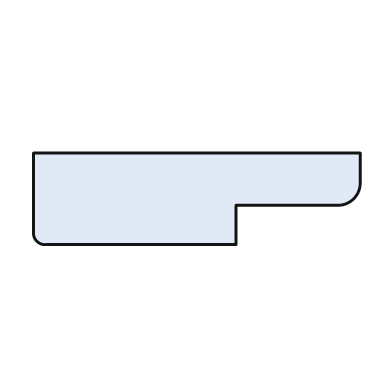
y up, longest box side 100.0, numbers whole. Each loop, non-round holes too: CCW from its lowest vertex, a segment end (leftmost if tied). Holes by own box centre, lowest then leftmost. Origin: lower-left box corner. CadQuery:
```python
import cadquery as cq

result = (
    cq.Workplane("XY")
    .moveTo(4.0, 0.0)
    .lineTo(62.0, 0.0)
    .lineTo(62.0, 12.0)
    .lineTo(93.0, 12.0)
    .threePointArc((98.0, 14.0), (100.0, 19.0))
    .lineTo(100.0, 28.0)
    .lineTo(0.0, 28.0)
    .lineTo(0.0, 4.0)
    .threePointArc((1.0, 1.0), (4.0, 0.0))
    .close()
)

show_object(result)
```